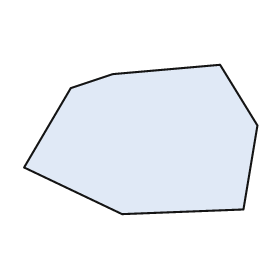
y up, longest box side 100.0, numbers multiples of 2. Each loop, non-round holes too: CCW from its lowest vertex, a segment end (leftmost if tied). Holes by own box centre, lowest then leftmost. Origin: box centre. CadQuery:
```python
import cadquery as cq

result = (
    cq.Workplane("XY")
    .moveTo(-8.0, -32.0)
    .lineTo(44.0, -30.0)
    .lineTo(50.0, 6.0)
    .lineTo(34.0, 32.0)
    .lineTo(-12.0, 28.0)
    .lineTo(-30.0, 22.0)
    .lineTo(-50.0, -12.0)
    .close()
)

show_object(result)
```